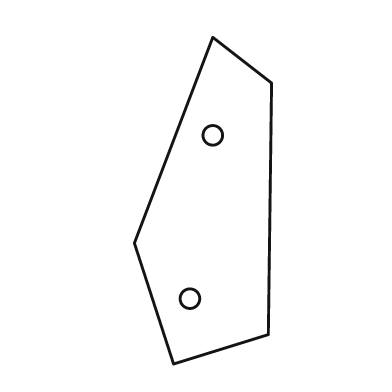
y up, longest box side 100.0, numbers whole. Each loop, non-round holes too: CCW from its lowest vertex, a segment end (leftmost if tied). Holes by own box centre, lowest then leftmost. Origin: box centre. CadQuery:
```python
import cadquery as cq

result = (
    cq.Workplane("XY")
    .moveTo(-9.0, -50.0)
    .lineTo(20.0, -41.0)
    .lineTo(21.0, 36.0)
    .lineTo(3.0, 50.0)
    .lineTo(-21.0, -13.0)
    .close()
    .moveTo(-4.0, -30.0)
    .circle(3.0)
    .moveTo(3.0, 20.0)
    .circle(3.0)
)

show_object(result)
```